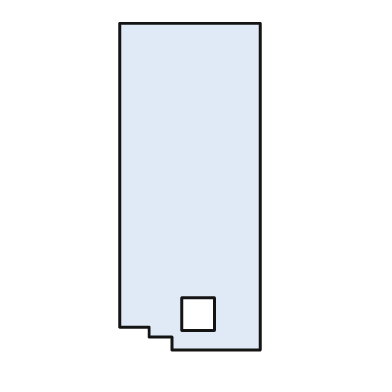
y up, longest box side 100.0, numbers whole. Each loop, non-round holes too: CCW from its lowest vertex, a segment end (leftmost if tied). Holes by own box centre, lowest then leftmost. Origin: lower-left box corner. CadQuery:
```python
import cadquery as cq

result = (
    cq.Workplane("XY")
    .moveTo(16.0, 0.0)
    .lineTo(43.0, 0.0)
    .lineTo(43.0, 100.0)
    .lineTo(0.0, 100.0)
    .lineTo(0.0, 7.0)
    .lineTo(9.0, 7.0)
    .lineTo(9.0, 4.0)
    .lineTo(16.0, 4.0)
    .close()
    .moveTo(19.0, 6.0)
    .lineTo(29.0, 6.0)
    .lineTo(29.0, 16.0)
    .lineTo(19.0, 16.0)
    .close()
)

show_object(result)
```